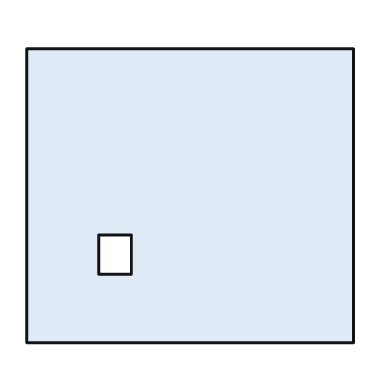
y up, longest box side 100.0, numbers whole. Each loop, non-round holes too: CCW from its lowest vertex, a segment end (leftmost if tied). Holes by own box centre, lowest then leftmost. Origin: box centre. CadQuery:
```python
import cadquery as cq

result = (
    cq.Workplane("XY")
    .moveTo(-50.0, -45.0)
    .lineTo(50.0, -45.0)
    .lineTo(50.0, 45.0)
    .lineTo(-50.0, 45.0)
    .close()
    .moveTo(-28.0, -24.0)
    .lineTo(-18.0, -24.0)
    .lineTo(-18.0, -12.0)
    .lineTo(-28.0, -12.0)
    .close()
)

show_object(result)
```